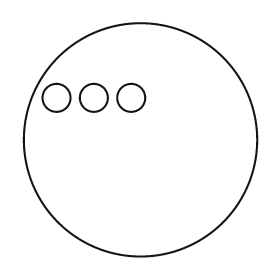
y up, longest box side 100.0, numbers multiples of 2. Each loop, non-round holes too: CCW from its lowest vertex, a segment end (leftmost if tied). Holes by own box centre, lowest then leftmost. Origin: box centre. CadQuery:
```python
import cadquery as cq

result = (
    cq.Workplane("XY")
    .moveTo(0.0, 0.0)
    .circle(50.0)
    .moveTo(-36.0, 18.0)
    .circle(6.0)
    .moveTo(-20.0, 18.0)
    .circle(6.0)
    .moveTo(-4.0, 18.0)
    .circle(6.0)
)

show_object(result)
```